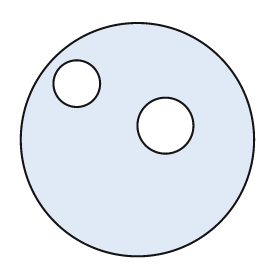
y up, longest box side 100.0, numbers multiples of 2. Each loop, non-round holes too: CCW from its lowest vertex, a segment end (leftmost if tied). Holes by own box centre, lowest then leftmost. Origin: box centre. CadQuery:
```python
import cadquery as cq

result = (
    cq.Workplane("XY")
    .moveTo(0.0, 0.0)
    .circle(50.0)
    .moveTo(12.0, 6.0)
    .circle(12.0)
    .moveTo(-26.0, 24.0)
    .circle(10.0)
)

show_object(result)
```